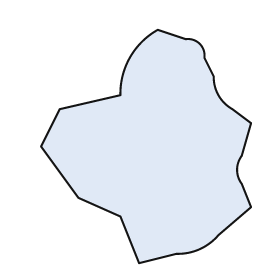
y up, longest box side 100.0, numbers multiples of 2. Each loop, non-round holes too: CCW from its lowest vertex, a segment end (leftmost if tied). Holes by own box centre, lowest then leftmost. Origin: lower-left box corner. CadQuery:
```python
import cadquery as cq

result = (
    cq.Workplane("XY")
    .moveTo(42.0, 0.0)
    .lineTo(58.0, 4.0)
    .threePointArc((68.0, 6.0), (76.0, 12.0))
    .lineTo(90.0, 24.0)
    .lineTo(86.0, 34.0)
    .threePointArc((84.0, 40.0), (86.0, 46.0))
    .lineTo(90.0, 60.0)
    .lineTo(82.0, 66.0)
    .threePointArc((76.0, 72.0), (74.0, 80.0))
    .lineTo(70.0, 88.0)
    .threePointArc((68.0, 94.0), (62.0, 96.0))
    .lineTo(50.0, 100.0)
    .threePointArc((38.0, 88.0), (34.0, 72.0))
    .lineTo(8.0, 66.0)
    .lineTo(0.0, 50.0)
    .lineTo(16.0, 28.0)
    .lineTo(34.0, 20.0)
    .close()
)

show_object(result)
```